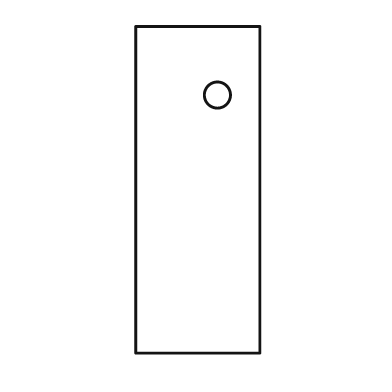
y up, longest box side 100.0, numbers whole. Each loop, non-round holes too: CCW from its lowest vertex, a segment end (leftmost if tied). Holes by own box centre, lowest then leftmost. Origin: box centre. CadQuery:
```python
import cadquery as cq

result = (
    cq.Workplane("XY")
    .moveTo(-19.0, -50.0)
    .lineTo(19.0, -50.0)
    .lineTo(19.0, 50.0)
    .lineTo(-19.0, 50.0)
    .close()
    .moveTo(6.0, 29.0)
    .circle(4.0)
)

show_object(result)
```